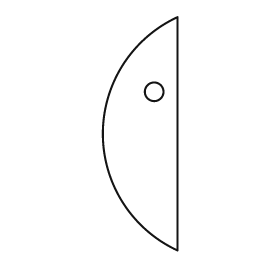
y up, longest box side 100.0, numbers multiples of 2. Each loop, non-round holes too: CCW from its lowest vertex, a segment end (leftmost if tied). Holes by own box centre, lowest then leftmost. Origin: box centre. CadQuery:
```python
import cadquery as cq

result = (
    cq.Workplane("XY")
    .moveTo(16.0, -50.0)
    .lineTo(16.0, 50.0)
    .threePointArc((-16.0, 0.0), (16.0, -50.0))
    .close()
    .moveTo(6.0, 18.0)
    .circle(4.0)
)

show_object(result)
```